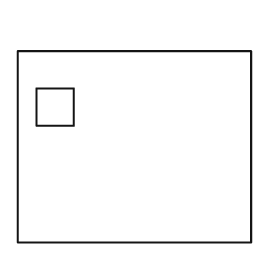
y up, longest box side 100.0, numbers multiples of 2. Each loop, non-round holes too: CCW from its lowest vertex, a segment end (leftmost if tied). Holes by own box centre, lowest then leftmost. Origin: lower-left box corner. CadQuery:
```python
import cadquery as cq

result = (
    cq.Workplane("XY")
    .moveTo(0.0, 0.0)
    .lineTo(100.0, 0.0)
    .lineTo(100.0, 82.0)
    .lineTo(0.0, 82.0)
    .close()
    .moveTo(8.0, 50.0)
    .lineTo(24.0, 50.0)
    .lineTo(24.0, 66.0)
    .lineTo(8.0, 66.0)
    .close()
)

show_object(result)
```